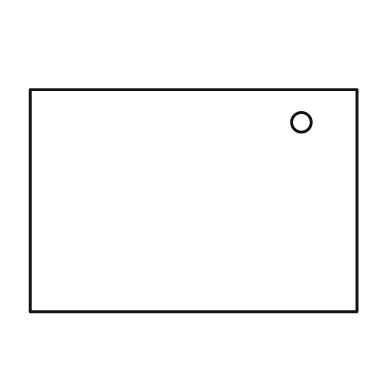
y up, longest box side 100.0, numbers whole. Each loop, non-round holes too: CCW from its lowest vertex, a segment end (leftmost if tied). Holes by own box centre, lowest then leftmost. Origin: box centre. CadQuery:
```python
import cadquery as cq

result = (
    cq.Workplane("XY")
    .moveTo(-50.0, -34.0)
    .lineTo(50.0, -34.0)
    .lineTo(50.0, 34.0)
    .lineTo(-50.0, 34.0)
    .close()
    .moveTo(33.0, 24.0)
    .circle(3.0)
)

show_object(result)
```